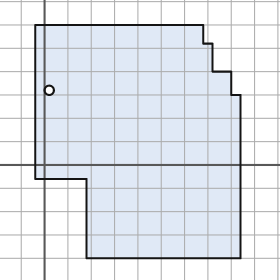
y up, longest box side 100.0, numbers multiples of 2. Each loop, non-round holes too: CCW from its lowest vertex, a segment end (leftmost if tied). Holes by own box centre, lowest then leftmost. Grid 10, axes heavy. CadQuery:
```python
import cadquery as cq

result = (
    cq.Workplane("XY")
    .moveTo(18.0, -40.0)
    .lineTo(84.0, -40.0)
    .lineTo(84.0, 30.0)
    .lineTo(80.0, 30.0)
    .lineTo(80.0, 40.0)
    .lineTo(72.0, 40.0)
    .lineTo(72.0, 52.0)
    .lineTo(68.0, 52.0)
    .lineTo(68.0, 60.0)
    .lineTo(-4.0, 60.0)
    .lineTo(-4.0, -6.0)
    .lineTo(18.0, -6.0)
    .close()
    .moveTo(2.0, 32.0)
    .circle(2.0)
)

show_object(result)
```